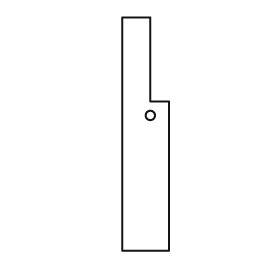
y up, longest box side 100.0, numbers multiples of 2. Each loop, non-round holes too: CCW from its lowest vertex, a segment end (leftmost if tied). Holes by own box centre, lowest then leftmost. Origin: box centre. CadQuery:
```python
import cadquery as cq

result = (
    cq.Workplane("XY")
    .moveTo(-10.0, -50.0)
    .lineTo(10.0, -50.0)
    .lineTo(10.0, 14.0)
    .lineTo(2.0, 14.0)
    .lineTo(2.0, 50.0)
    .lineTo(-10.0, 50.0)
    .close()
    .moveTo(2.0, 8.0)
    .circle(2.0)
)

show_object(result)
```